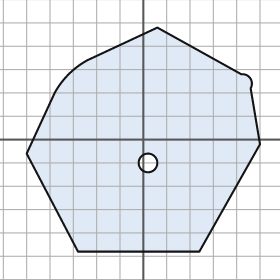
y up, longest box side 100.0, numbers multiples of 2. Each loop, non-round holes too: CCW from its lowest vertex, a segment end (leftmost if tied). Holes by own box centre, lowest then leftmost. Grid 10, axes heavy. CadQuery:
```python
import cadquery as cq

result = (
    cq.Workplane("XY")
    .moveTo(-28.0, -48.0)
    .lineTo(24.0, -48.0)
    .lineTo(50.0, -2.0)
    .lineTo(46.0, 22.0)
    .threePointArc((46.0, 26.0), (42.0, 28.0))
    .lineTo(6.0, 48.0)
    .lineTo(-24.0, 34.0)
    .threePointArc((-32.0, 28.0), (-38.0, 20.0))
    .lineTo(-50.0, -6.0)
    .close()
    .moveTo(2.0, -10.0)
    .circle(4.0)
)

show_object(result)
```